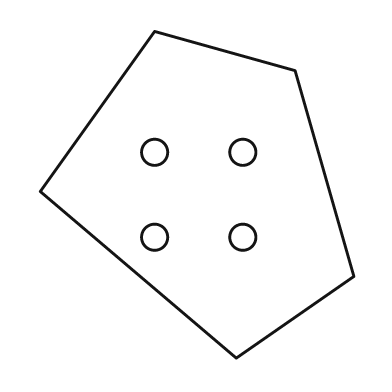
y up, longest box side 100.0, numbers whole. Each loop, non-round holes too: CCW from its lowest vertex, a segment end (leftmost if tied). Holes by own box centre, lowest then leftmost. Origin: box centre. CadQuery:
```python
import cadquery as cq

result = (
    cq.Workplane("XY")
    .moveTo(12.0, -50.0)
    .lineTo(48.0, -25.0)
    .lineTo(30.0, 38.0)
    .lineTo(-13.0, 50.0)
    .lineTo(-48.0, 1.0)
    .close()
    .moveTo(-13.0, -13.0)
    .circle(4.0)
    .moveTo(14.0, -13.0)
    .circle(4.0)
    .moveTo(-13.0, 13.0)
    .circle(4.0)
    .moveTo(14.0, 13.0)
    .circle(4.0)
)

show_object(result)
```